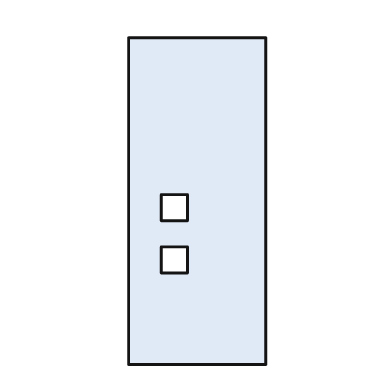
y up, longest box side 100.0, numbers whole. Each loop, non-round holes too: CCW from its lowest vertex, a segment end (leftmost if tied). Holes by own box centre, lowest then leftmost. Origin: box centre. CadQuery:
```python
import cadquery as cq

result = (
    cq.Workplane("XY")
    .moveTo(-21.0, -50.0)
    .lineTo(21.0, -50.0)
    .lineTo(21.0, 50.0)
    .lineTo(-21.0, 50.0)
    .close()
    .moveTo(-11.0, -22.0)
    .lineTo(-3.0, -22.0)
    .lineTo(-3.0, -14.0)
    .lineTo(-11.0, -14.0)
    .close()
    .moveTo(-11.0, -6.0)
    .lineTo(-3.0, -6.0)
    .lineTo(-3.0, 2.0)
    .lineTo(-11.0, 2.0)
    .close()
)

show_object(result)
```